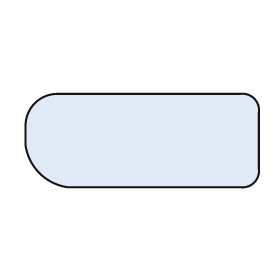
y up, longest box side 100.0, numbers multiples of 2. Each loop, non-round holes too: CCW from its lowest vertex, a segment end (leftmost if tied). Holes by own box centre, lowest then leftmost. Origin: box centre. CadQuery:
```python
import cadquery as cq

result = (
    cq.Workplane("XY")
    .moveTo(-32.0, -20.0)
    .lineTo(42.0, -20.0)
    .threePointArc((48.0, -18.0), (50.0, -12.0))
    .lineTo(50.0, 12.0)
    .threePointArc((48.0, 18.0), (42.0, 20.0))
    .lineTo(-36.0, 20.0)
    .threePointArc((-46.0, 16.0), (-50.0, 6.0))
    .lineTo(-50.0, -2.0)
    .threePointArc((-44.0, -14.0), (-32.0, -20.0))
    .close()
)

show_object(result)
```